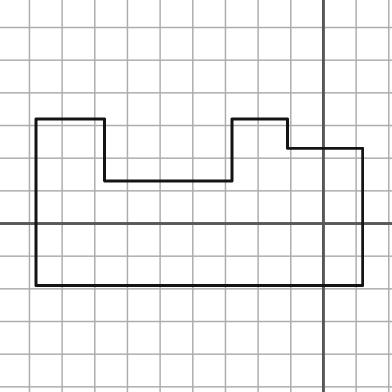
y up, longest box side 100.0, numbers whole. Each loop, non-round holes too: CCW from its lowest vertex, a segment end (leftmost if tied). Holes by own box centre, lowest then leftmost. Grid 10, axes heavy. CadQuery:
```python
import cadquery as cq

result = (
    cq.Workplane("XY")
    .moveTo(-88.0, -19.0)
    .lineTo(12.0, -19.0)
    .lineTo(12.0, 23.0)
    .lineTo(-11.0, 23.0)
    .lineTo(-11.0, 32.0)
    .lineTo(-28.0, 32.0)
    .lineTo(-28.0, 13.0)
    .lineTo(-67.0, 13.0)
    .lineTo(-67.0, 32.0)
    .lineTo(-88.0, 32.0)
    .close()
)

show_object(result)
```